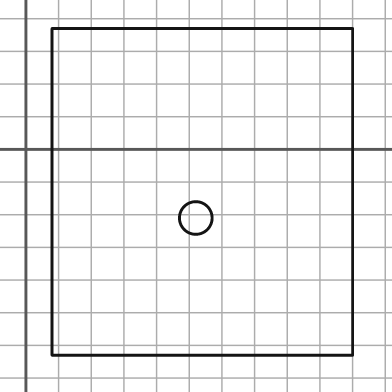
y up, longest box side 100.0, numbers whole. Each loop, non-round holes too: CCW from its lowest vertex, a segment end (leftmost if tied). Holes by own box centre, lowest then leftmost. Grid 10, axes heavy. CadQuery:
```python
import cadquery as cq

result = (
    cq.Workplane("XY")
    .moveTo(8.0, -63.0)
    .lineTo(100.0, -63.0)
    .lineTo(100.0, 37.0)
    .lineTo(8.0, 37.0)
    .close()
    .moveTo(52.0, -21.0)
    .circle(5.0)
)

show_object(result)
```